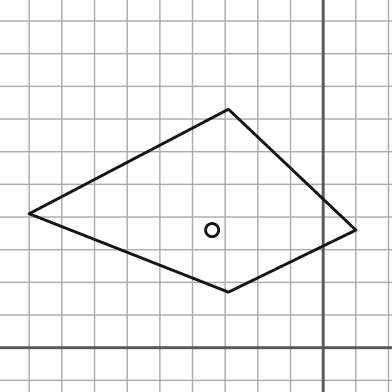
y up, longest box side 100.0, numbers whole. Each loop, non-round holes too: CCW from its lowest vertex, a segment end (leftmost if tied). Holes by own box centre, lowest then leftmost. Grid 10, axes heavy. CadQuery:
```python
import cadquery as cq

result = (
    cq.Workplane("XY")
    .moveTo(-29.0, 17.0)
    .lineTo(10.0, 36.0)
    .lineTo(-29.0, 73.0)
    .lineTo(-90.0, 41.0)
    .close()
    .moveTo(-34.0, 36.0)
    .circle(2.0)
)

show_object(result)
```